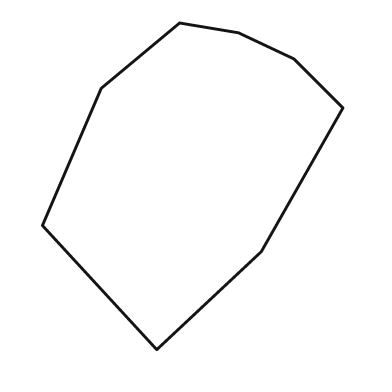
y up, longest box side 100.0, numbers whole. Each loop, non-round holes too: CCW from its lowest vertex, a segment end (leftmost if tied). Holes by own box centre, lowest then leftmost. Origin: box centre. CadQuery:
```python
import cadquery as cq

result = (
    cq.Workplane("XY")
    .moveTo(-11.0, -50.0)
    .lineTo(21.0, -20.0)
    .lineTo(46.0, 24.0)
    .lineTo(31.0, 39.0)
    .lineTo(14.0, 47.0)
    .lineTo(-4.0, 50.0)
    .lineTo(-28.0, 30.0)
    .lineTo(-46.0, -12.0)
    .close()
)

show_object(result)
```